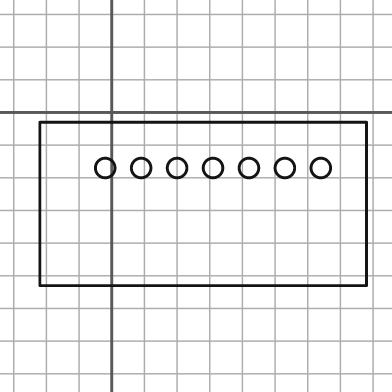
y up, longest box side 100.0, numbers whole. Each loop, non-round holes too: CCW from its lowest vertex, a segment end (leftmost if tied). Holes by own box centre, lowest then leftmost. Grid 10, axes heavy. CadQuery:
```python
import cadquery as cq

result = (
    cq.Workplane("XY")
    .moveTo(-22.0, -53.0)
    .lineTo(78.0, -53.0)
    .lineTo(78.0, -3.0)
    .lineTo(-22.0, -3.0)
    .close()
    .moveTo(-2.0, -17.0)
    .circle(3.0)
    .moveTo(9.0, -17.0)
    .circle(3.0)
    .moveTo(20.0, -17.0)
    .circle(3.0)
    .moveTo(31.0, -17.0)
    .circle(3.0)
    .moveTo(42.0, -17.0)
    .circle(3.0)
    .moveTo(53.0, -17.0)
    .circle(3.0)
    .moveTo(64.0, -17.0)
    .circle(3.0)
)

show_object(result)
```